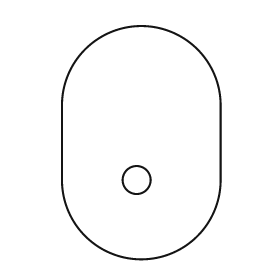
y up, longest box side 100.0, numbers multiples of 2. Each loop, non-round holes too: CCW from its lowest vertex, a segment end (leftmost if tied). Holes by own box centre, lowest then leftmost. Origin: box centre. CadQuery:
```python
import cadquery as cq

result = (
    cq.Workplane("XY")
    .moveTo(-34.0, -16.0)
    .threePointArc((0.0, -50.0), (34.0, -16.0))
    .lineTo(34.0, 16.0)
    .threePointArc((0.0, 50.0), (-34.0, 16.0))
    .close()
    .moveTo(-2.0, -16.0)
    .circle(6.0)
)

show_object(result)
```